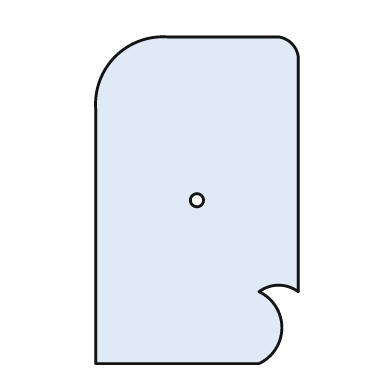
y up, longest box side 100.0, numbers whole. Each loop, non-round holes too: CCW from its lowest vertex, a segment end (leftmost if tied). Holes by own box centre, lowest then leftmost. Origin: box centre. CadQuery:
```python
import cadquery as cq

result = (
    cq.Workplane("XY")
    .moveTo(-31.0, -50.0)
    .lineTo(19.0, -50.0)
    .threePointArc((26.0, -39.0), (19.0, -28.0))
    .threePointArc((25.0, -26.0), (31.0, -28.0))
    .lineTo(31.0, 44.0)
    .threePointArc((29.0, 48.0), (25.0, 50.0))
    .lineTo(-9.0, 50.0)
    .threePointArc((-25.0, 44.0), (-31.0, 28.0))
    .close()
    .moveTo(0.0, 0.0)
    .circle(2.0)
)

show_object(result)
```